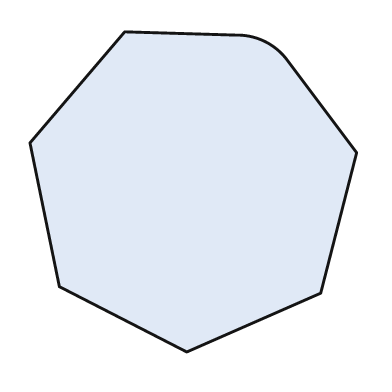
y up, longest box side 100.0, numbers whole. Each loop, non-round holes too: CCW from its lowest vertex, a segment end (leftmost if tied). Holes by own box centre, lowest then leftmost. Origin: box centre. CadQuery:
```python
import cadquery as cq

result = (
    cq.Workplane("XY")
    .moveTo(-2.0, -49.0)
    .lineTo(39.0, -31.0)
    .lineTo(50.0, 12.0)
    .lineTo(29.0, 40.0)
    .threePointArc((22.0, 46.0), (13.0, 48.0))
    .lineTo(-21.0, 49.0)
    .lineTo(-50.0, 15.0)
    .lineTo(-41.0, -29.0)
    .close()
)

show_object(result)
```